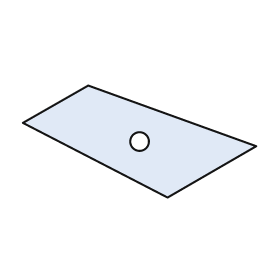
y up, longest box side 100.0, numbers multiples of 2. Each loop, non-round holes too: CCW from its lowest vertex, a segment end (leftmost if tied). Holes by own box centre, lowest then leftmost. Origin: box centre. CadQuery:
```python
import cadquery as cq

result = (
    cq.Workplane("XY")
    .moveTo(12.0, -24.0)
    .lineTo(50.0, -2.0)
    .lineTo(-22.0, 24.0)
    .lineTo(-50.0, 8.0)
    .close()
    .moveTo(0.0, 0.0)
    .circle(4.0)
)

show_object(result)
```